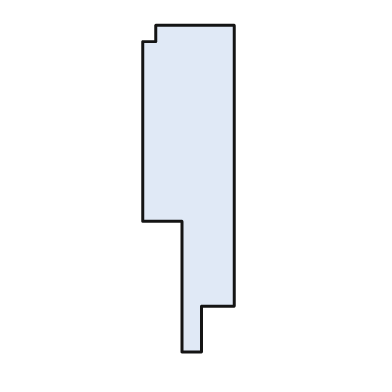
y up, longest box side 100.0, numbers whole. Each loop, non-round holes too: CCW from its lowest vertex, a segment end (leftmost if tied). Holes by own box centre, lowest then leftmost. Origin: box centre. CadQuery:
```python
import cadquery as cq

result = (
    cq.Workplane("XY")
    .moveTo(-2.0, -50.0)
    .lineTo(4.0, -50.0)
    .lineTo(4.0, -36.0)
    .lineTo(14.0, -36.0)
    .lineTo(14.0, 50.0)
    .lineTo(-10.0, 50.0)
    .lineTo(-10.0, 45.0)
    .lineTo(-14.0, 45.0)
    .lineTo(-14.0, -10.0)
    .lineTo(-2.0, -10.0)
    .close()
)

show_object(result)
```